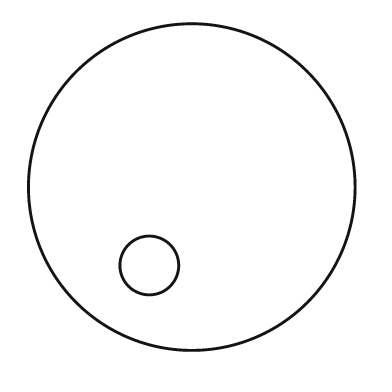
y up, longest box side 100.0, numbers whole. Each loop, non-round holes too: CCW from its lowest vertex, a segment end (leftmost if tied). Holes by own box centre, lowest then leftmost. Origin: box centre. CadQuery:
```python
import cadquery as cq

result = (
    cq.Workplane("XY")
    .moveTo(0.0, 0.0)
    .circle(50.0)
    .moveTo(-13.0, -24.0)
    .circle(9.0)
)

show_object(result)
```